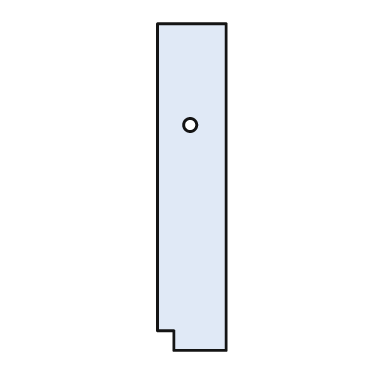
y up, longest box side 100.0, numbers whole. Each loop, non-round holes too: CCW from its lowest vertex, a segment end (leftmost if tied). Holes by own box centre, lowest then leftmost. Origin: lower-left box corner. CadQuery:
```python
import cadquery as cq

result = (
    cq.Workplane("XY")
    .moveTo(5.0, 0.0)
    .lineTo(21.0, 0.0)
    .lineTo(21.0, 100.0)
    .lineTo(0.0, 100.0)
    .lineTo(0.0, 6.0)
    .lineTo(5.0, 6.0)
    .close()
    .moveTo(10.0, 69.0)
    .circle(2.0)
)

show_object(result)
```